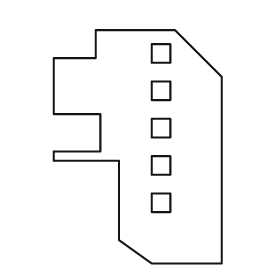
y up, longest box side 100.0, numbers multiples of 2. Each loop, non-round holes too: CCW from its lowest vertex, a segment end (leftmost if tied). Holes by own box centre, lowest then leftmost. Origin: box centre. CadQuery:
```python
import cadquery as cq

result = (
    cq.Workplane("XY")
    .moveTo(6.0, -50.0)
    .lineTo(36.0, -50.0)
    .lineTo(36.0, 30.0)
    .lineTo(16.0, 50.0)
    .lineTo(-18.0, 50.0)
    .lineTo(-18.0, 38.0)
    .lineTo(-36.0, 38.0)
    .lineTo(-36.0, 14.0)
    .lineTo(-16.0, 14.0)
    .lineTo(-16.0, -2.0)
    .lineTo(-36.0, -2.0)
    .lineTo(-36.0, -6.0)
    .lineTo(-8.0, -6.0)
    .lineTo(-8.0, -40.0)
    .close()
    .moveTo(6.0, -28.0)
    .lineTo(14.0, -28.0)
    .lineTo(14.0, -20.0)
    .lineTo(6.0, -20.0)
    .close()
    .moveTo(6.0, -12.0)
    .lineTo(14.0, -12.0)
    .lineTo(14.0, -4.0)
    .lineTo(6.0, -4.0)
    .close()
    .moveTo(6.0, 4.0)
    .lineTo(14.0, 4.0)
    .lineTo(14.0, 12.0)
    .lineTo(6.0, 12.0)
    .close()
    .moveTo(6.0, 20.0)
    .lineTo(14.0, 20.0)
    .lineTo(14.0, 28.0)
    .lineTo(6.0, 28.0)
    .close()
    .moveTo(6.0, 36.0)
    .lineTo(14.0, 36.0)
    .lineTo(14.0, 44.0)
    .lineTo(6.0, 44.0)
    .close()
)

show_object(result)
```